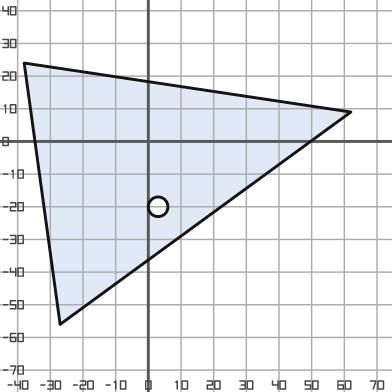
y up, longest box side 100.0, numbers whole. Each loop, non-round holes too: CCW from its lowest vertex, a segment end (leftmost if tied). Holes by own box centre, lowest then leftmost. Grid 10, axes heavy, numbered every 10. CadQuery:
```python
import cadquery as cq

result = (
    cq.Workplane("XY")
    .moveTo(-27.0, -56.0)
    .lineTo(62.0, 9.0)
    .lineTo(-38.0, 24.0)
    .close()
    .moveTo(3.0, -20.0)
    .circle(3.0)
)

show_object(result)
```